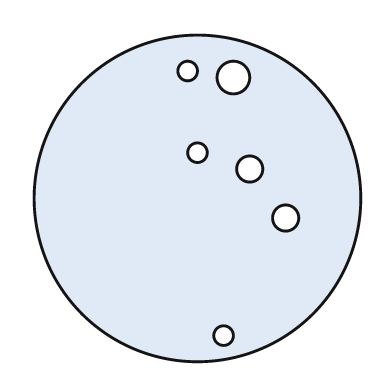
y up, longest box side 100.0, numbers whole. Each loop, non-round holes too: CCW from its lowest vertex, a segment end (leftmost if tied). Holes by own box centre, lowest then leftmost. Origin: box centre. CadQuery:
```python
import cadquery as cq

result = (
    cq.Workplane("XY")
    .moveTo(0.0, 0.0)
    .circle(50.0)
    .moveTo(8.0, -42.0)
    .circle(3.0)
    .moveTo(27.0, -6.0)
    .circle(4.0)
    .moveTo(16.0, 9.0)
    .circle(4.0)
    .moveTo(0.0, 14.0)
    .circle(3.0)
    .moveTo(11.0, 37.0)
    .circle(5.0)
    .moveTo(-3.0, 39.0)
    .circle(3.0)
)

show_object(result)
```